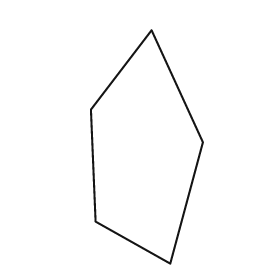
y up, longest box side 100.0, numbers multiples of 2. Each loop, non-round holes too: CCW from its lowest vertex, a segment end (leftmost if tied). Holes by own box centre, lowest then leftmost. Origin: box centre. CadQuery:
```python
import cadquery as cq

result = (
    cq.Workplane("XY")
    .moveTo(10.0, -50.0)
    .lineTo(24.0, 2.0)
    .lineTo(2.0, 50.0)
    .lineTo(-24.0, 16.0)
    .lineTo(-22.0, -32.0)
    .close()
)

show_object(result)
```